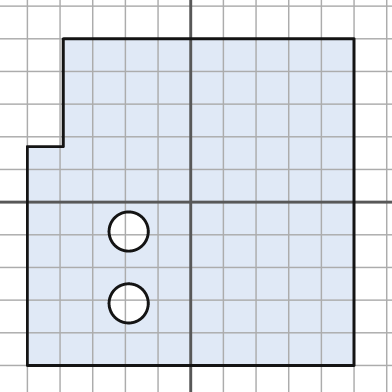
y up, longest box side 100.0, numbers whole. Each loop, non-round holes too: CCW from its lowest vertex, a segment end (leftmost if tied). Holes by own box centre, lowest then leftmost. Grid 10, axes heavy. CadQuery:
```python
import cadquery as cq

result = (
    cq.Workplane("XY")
    .moveTo(-50.0, -50.0)
    .lineTo(50.0, -50.0)
    .lineTo(50.0, 50.0)
    .lineTo(-39.0, 50.0)
    .lineTo(-39.0, 17.0)
    .lineTo(-50.0, 17.0)
    .close()
    .moveTo(-19.0, -31.0)
    .circle(6.0)
    .moveTo(-19.0, -9.0)
    .circle(6.0)
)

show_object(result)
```